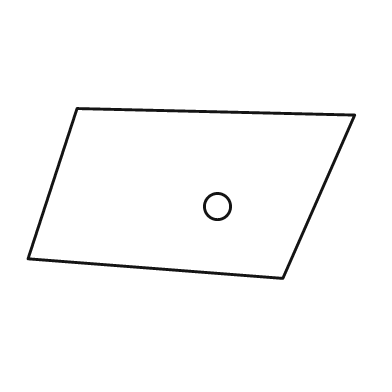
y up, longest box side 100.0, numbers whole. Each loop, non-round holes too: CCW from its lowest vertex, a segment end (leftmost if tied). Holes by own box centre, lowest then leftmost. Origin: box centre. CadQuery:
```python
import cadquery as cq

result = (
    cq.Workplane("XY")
    .moveTo(28.0, -26.0)
    .lineTo(50.0, 24.0)
    .lineTo(-35.0, 26.0)
    .lineTo(-50.0, -20.0)
    .close()
    .moveTo(8.0, -4.0)
    .circle(4.0)
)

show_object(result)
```